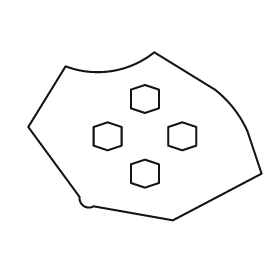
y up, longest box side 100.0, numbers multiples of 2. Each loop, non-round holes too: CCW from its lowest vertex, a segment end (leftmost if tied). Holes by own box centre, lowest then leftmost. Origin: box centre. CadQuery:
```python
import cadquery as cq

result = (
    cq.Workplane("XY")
    .moveTo(12.0, -36.0)
    .lineTo(50.0, -16.0)
    .lineTo(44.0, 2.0)
    .threePointArc((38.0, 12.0), (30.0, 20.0))
    .lineTo(4.0, 36.0)
    .threePointArc((-14.0, 28.0), (-34.0, 30.0))
    .lineTo(-50.0, 4.0)
    .lineTo(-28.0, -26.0)
    .threePointArc((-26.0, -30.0), (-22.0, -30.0))
    .close()
    .moveTo(0.0, -22.0)
    .lineTo(6.0, -20.0)
    .lineTo(6.0, -12.0)
    .lineTo(0.0, -10.0)
    .lineTo(-6.0, -12.0)
    .lineTo(-6.0, -20.0)
    .close()
    .moveTo(-16.0, -6.0)
    .lineTo(-10.0, -4.0)
    .lineTo(-10.0, 4.0)
    .lineTo(-16.0, 6.0)
    .lineTo(-22.0, 4.0)
    .lineTo(-22.0, -4.0)
    .close()
    .moveTo(16.0, -6.0)
    .lineTo(22.0, -4.0)
    .lineTo(22.0, 4.0)
    .lineTo(16.0, 6.0)
    .lineTo(10.0, 4.0)
    .lineTo(10.0, -4.0)
    .close()
    .moveTo(0.0, 10.0)
    .lineTo(6.0, 12.0)
    .lineTo(6.0, 20.0)
    .lineTo(0.0, 22.0)
    .lineTo(-6.0, 20.0)
    .lineTo(-6.0, 12.0)
    .close()
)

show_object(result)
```